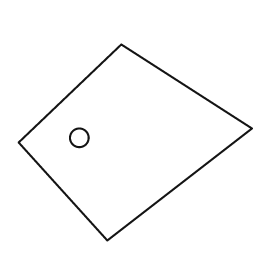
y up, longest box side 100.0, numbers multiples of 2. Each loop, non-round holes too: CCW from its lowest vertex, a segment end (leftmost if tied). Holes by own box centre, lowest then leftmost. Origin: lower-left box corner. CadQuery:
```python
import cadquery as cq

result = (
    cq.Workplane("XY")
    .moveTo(38.0, 0.0)
    .lineTo(100.0, 48.0)
    .lineTo(44.0, 84.0)
    .lineTo(0.0, 42.0)
    .close()
    .moveTo(26.0, 44.0)
    .circle(4.0)
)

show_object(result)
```